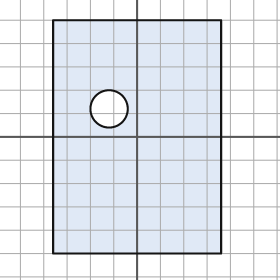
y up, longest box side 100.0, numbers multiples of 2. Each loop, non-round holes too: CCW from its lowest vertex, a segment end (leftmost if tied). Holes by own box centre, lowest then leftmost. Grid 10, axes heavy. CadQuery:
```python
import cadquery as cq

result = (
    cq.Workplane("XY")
    .moveTo(-36.0, -50.0)
    .lineTo(36.0, -50.0)
    .lineTo(36.0, 50.0)
    .lineTo(-36.0, 50.0)
    .close()
    .moveTo(-12.0, 12.0)
    .circle(8.0)
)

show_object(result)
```